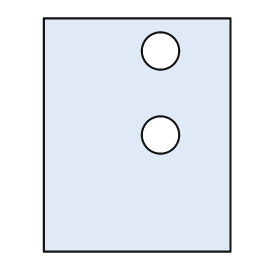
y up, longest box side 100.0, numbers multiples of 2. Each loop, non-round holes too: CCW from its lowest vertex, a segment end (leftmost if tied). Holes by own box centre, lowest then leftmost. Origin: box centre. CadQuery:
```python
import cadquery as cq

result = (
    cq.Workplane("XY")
    .moveTo(-40.0, -50.0)
    .lineTo(40.0, -50.0)
    .lineTo(40.0, 50.0)
    .lineTo(-40.0, 50.0)
    .close()
    .moveTo(10.0, 0.0)
    .circle(8.0)
    .moveTo(10.0, 36.0)
    .circle(8.0)
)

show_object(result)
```